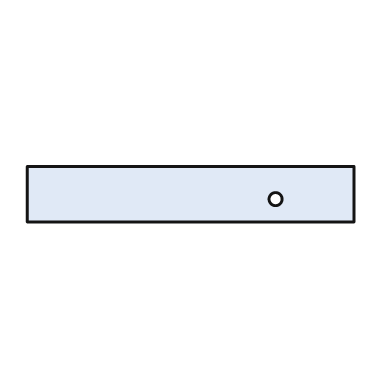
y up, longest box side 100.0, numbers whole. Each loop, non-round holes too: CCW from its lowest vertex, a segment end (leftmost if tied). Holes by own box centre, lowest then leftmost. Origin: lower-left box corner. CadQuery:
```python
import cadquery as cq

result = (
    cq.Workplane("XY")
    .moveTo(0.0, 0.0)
    .lineTo(100.0, 0.0)
    .lineTo(100.0, 17.0)
    .lineTo(0.0, 17.0)
    .close()
    .moveTo(76.0, 7.0)
    .circle(2.0)
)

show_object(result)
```